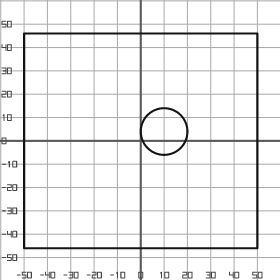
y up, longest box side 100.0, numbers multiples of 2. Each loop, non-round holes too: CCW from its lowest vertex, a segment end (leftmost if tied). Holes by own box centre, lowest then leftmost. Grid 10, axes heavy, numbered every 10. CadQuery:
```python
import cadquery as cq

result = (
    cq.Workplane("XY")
    .moveTo(-50.0, -46.0)
    .lineTo(50.0, -46.0)
    .lineTo(50.0, 46.0)
    .lineTo(-50.0, 46.0)
    .close()
    .moveTo(10.0, 4.0)
    .circle(10.0)
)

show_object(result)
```